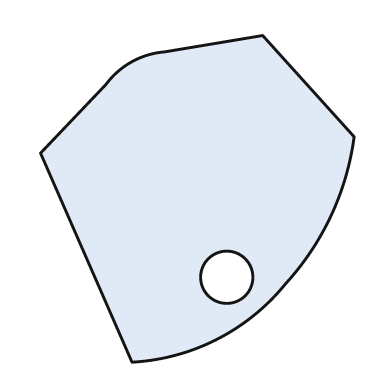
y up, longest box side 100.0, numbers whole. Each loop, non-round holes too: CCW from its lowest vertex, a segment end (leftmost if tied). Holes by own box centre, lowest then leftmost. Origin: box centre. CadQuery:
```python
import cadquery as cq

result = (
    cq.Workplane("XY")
    .moveTo(-20.0, -50.0)
    .threePointArc((6.0, -43.0), (27.0, -26.0))
    .threePointArc((41.0, -5.0), (48.0, 19.0))
    .lineTo(20.0, 50.0)
    .lineTo(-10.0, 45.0)
    .threePointArc((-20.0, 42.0), (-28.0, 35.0))
    .lineTo(-48.0, 14.0)
    .close()
    .moveTo(9.0, -24.0)
    .circle(8.0)
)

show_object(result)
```